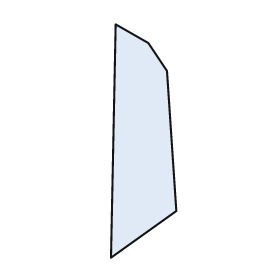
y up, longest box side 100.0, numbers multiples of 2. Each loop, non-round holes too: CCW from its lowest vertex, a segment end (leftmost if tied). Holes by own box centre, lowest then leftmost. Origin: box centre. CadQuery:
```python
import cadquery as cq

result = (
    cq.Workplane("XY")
    .moveTo(-14.0, -50.0)
    .lineTo(14.0, -30.0)
    .lineTo(10.0, 30.0)
    .lineTo(2.0, 42.0)
    .lineTo(-12.0, 50.0)
    .close()
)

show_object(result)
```